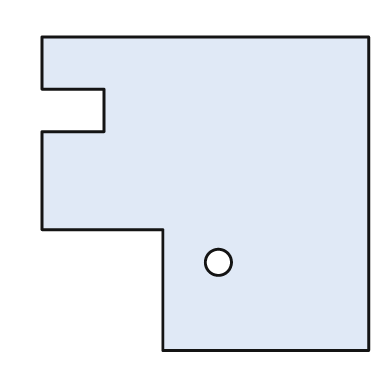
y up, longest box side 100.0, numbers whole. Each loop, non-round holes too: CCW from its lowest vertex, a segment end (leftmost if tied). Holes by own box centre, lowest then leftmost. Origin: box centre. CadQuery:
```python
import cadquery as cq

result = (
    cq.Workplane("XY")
    .moveTo(-13.0, -48.0)
    .lineTo(50.0, -48.0)
    .lineTo(50.0, 48.0)
    .lineTo(-50.0, 48.0)
    .lineTo(-50.0, 32.0)
    .lineTo(-31.0, 32.0)
    .lineTo(-31.0, 19.0)
    .lineTo(-50.0, 19.0)
    .lineTo(-50.0, -11.0)
    .lineTo(-13.0, -11.0)
    .close()
    .moveTo(4.0, -21.0)
    .circle(4.0)
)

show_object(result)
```